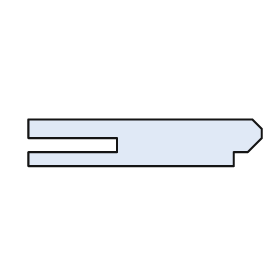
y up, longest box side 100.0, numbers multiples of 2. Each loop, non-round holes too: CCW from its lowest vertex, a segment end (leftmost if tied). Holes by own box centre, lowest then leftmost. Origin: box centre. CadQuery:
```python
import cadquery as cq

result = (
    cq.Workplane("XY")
    .moveTo(-50.0, -10.0)
    .lineTo(38.0, -10.0)
    .lineTo(38.0, -4.0)
    .lineTo(44.0, -4.0)
    .lineTo(50.0, 2.0)
    .lineTo(50.0, 6.0)
    .lineTo(46.0, 10.0)
    .lineTo(-50.0, 10.0)
    .lineTo(-50.0, 2.0)
    .lineTo(-12.0, 2.0)
    .lineTo(-12.0, -4.0)
    .lineTo(-50.0, -4.0)
    .close()
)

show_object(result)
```